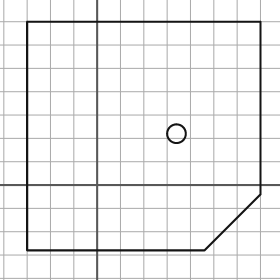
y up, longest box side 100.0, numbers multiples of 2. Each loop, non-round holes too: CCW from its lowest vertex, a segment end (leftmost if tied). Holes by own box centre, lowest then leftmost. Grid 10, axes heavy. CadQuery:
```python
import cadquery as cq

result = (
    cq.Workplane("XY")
    .moveTo(-30.0, -28.0)
    .lineTo(46.0, -28.0)
    .lineTo(70.0, -4.0)
    .lineTo(70.0, 70.0)
    .lineTo(-30.0, 70.0)
    .close()
    .moveTo(34.0, 22.0)
    .circle(4.0)
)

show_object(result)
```